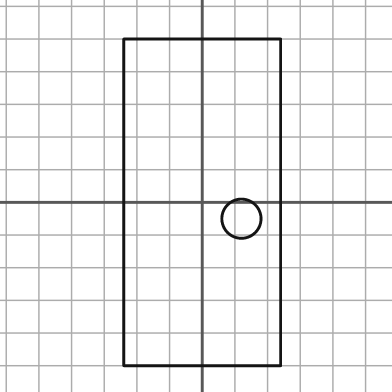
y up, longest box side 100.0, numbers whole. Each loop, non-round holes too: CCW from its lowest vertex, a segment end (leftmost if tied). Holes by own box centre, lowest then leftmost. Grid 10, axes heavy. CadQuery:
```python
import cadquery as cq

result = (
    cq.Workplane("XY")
    .moveTo(-24.0, -50.0)
    .lineTo(24.0, -50.0)
    .lineTo(24.0, 50.0)
    .lineTo(-24.0, 50.0)
    .close()
    .moveTo(12.0, -5.0)
    .circle(6.0)
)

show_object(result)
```